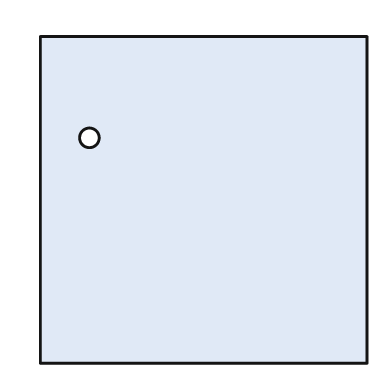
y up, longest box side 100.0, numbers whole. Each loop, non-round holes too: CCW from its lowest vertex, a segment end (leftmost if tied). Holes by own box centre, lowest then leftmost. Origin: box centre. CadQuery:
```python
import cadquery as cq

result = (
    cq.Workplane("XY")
    .moveTo(-50.0, -50.0)
    .lineTo(50.0, -50.0)
    .lineTo(50.0, 50.0)
    .lineTo(-50.0, 50.0)
    .close()
    .moveTo(-35.0, 19.0)
    .circle(3.0)
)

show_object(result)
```